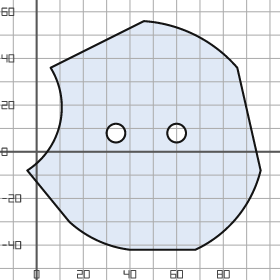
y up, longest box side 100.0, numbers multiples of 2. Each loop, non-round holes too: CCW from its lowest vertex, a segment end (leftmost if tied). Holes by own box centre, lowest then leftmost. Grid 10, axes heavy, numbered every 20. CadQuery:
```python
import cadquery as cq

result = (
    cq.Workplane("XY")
    .moveTo(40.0, -42.0)
    .lineTo(68.0, -42.0)
    .threePointArc((86.0, -28.0), (96.0, -8.0))
    .lineTo(86.0, 36.0)
    .threePointArc((68.0, 50.0), (46.0, 56.0))
    .lineTo(6.0, 36.0)
    .threePointArc((10.0, 12.0), (-4.0, -8.0))
    .lineTo(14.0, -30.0)
    .threePointArc((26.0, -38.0), (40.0, -42.0))
    .close()
    .moveTo(34.0, 8.0)
    .circle(4.0)
    .moveTo(60.0, 8.0)
    .circle(4.0)
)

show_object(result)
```